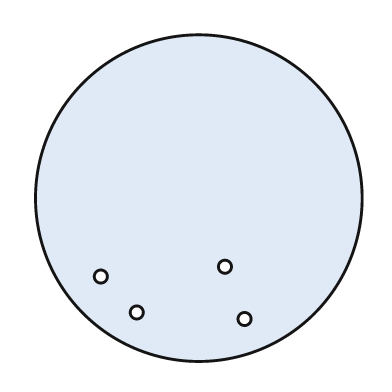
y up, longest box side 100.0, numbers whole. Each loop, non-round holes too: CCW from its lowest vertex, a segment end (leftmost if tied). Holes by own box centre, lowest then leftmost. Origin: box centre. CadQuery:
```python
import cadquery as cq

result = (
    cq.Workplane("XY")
    .moveTo(0.0, 0.0)
    .circle(50.0)
    .moveTo(14.0, -37.0)
    .circle(2.0)
    .moveTo(-19.0, -35.0)
    .circle(2.0)
    .moveTo(-30.0, -24.0)
    .circle(2.0)
    .moveTo(8.0, -21.0)
    .circle(2.0)
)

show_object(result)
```